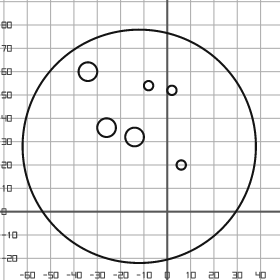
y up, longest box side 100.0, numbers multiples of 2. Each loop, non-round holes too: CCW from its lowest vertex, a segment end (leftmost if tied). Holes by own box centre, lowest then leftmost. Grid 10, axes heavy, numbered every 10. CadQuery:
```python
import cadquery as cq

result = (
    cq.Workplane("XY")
    .moveTo(-12.0, 28.0)
    .circle(50.0)
    .moveTo(6.0, 20.0)
    .circle(2.0)
    .moveTo(-14.0, 32.0)
    .circle(4.0)
    .moveTo(-26.0, 36.0)
    .circle(4.0)
    .moveTo(2.0, 52.0)
    .circle(2.0)
    .moveTo(-8.0, 54.0)
    .circle(2.0)
    .moveTo(-34.0, 60.0)
    .circle(4.0)
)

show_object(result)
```